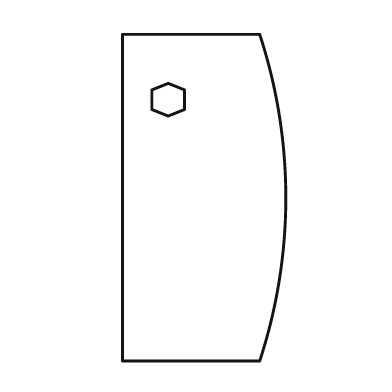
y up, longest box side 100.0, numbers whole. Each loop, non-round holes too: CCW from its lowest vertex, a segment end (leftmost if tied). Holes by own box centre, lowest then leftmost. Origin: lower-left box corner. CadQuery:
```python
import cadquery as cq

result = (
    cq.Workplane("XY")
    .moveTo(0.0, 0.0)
    .lineTo(42.0, 0.0)
    .threePointArc((50.0, 50.0), (42.0, 100.0))
    .lineTo(0.0, 100.0)
    .close()
    .moveTo(14.0, 75.0)
    .lineTo(19.0, 77.0)
    .lineTo(19.0, 83.0)
    .lineTo(14.0, 85.0)
    .lineTo(9.0, 83.0)
    .lineTo(9.0, 77.0)
    .close()
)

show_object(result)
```